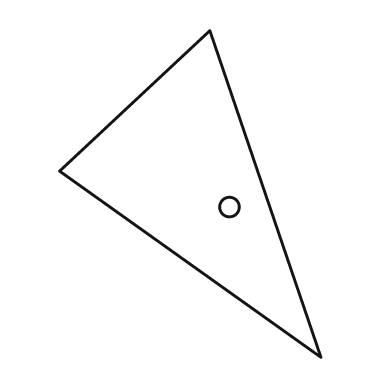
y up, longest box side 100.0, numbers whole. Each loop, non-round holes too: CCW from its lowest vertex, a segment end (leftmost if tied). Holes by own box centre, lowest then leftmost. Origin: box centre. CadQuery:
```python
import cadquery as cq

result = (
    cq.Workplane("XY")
    .moveTo(40.0, -50.0)
    .lineTo(6.0, 50.0)
    .lineTo(-40.0, 7.0)
    .close()
    .moveTo(12.0, -4.0)
    .circle(3.0)
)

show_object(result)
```